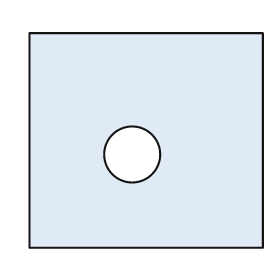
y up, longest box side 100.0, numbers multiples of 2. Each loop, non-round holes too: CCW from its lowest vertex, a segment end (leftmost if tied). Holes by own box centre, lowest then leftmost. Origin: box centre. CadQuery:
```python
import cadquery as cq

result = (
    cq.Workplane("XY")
    .moveTo(-50.0, -46.0)
    .lineTo(50.0, -46.0)
    .lineTo(50.0, 46.0)
    .lineTo(-50.0, 46.0)
    .close()
    .moveTo(-6.0, -6.0)
    .circle(12.0)
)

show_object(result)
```